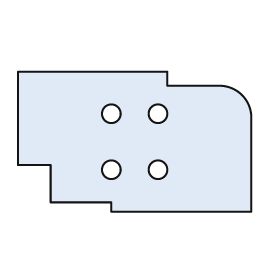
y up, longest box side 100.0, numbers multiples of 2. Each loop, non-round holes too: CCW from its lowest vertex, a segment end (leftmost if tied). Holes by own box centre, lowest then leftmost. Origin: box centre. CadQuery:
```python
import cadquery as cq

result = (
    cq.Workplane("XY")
    .moveTo(-10.0, -30.0)
    .lineTo(50.0, -30.0)
    .lineTo(50.0, 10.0)
    .threePointArc((46.0, 20.0), (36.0, 24.0))
    .lineTo(14.0, 24.0)
    .lineTo(14.0, 30.0)
    .lineTo(-50.0, 30.0)
    .lineTo(-50.0, -10.0)
    .lineTo(-36.0, -10.0)
    .lineTo(-36.0, -26.0)
    .lineTo(-10.0, -26.0)
    .close()
    .moveTo(-10.0, -12.0)
    .circle(4.0)
    .moveTo(10.0, -12.0)
    .circle(4.0)
    .moveTo(-10.0, 12.0)
    .circle(4.0)
    .moveTo(10.0, 12.0)
    .circle(4.0)
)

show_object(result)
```